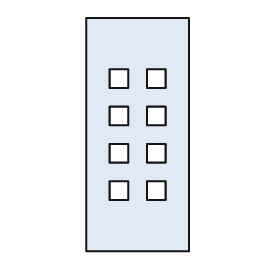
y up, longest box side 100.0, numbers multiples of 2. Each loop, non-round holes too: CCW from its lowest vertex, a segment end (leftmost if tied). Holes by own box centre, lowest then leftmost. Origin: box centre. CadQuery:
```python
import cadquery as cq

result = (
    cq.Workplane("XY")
    .moveTo(-22.0, -50.0)
    .lineTo(22.0, -50.0)
    .lineTo(22.0, 50.0)
    .lineTo(-22.0, 50.0)
    .close()
    .moveTo(-12.0, -28.0)
    .lineTo(-4.0, -28.0)
    .lineTo(-4.0, -20.0)
    .lineTo(-12.0, -20.0)
    .close()
    .moveTo(4.0, -28.0)
    .lineTo(12.0, -28.0)
    .lineTo(12.0, -20.0)
    .lineTo(4.0, -20.0)
    .close()
    .moveTo(-12.0, -12.0)
    .lineTo(-4.0, -12.0)
    .lineTo(-4.0, -4.0)
    .lineTo(-12.0, -4.0)
    .close()
    .moveTo(4.0, -12.0)
    .lineTo(12.0, -12.0)
    .lineTo(12.0, -4.0)
    .lineTo(4.0, -4.0)
    .close()
    .moveTo(-12.0, 4.0)
    .lineTo(-4.0, 4.0)
    .lineTo(-4.0, 12.0)
    .lineTo(-12.0, 12.0)
    .close()
    .moveTo(4.0, 4.0)
    .lineTo(12.0, 4.0)
    .lineTo(12.0, 12.0)
    .lineTo(4.0, 12.0)
    .close()
    .moveTo(-12.0, 20.0)
    .lineTo(-4.0, 20.0)
    .lineTo(-4.0, 28.0)
    .lineTo(-12.0, 28.0)
    .close()
    .moveTo(4.0, 20.0)
    .lineTo(12.0, 20.0)
    .lineTo(12.0, 28.0)
    .lineTo(4.0, 28.0)
    .close()
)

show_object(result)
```